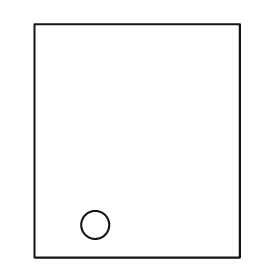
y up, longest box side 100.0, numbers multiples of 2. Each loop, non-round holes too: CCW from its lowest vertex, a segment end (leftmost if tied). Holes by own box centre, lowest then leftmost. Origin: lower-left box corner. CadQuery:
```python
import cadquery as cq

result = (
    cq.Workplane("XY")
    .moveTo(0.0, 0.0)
    .lineTo(88.0, 0.0)
    .lineTo(88.0, 100.0)
    .lineTo(0.0, 100.0)
    .close()
    .moveTo(26.0, 14.0)
    .circle(6.0)
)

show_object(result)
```